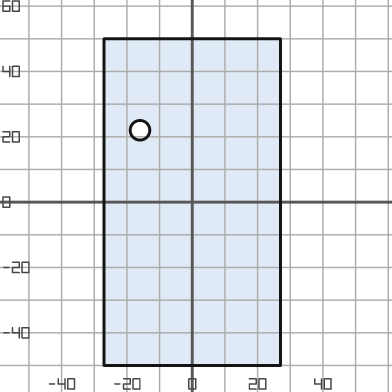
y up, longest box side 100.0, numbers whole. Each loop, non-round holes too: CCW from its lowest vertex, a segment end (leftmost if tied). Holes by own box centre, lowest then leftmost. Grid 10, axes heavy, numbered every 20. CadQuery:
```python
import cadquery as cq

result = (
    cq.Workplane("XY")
    .moveTo(-27.0, -50.0)
    .lineTo(27.0, -50.0)
    .lineTo(27.0, 50.0)
    .lineTo(-27.0, 50.0)
    .close()
    .moveTo(-16.0, 22.0)
    .circle(3.0)
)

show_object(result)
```